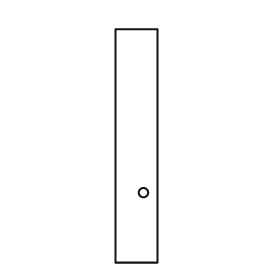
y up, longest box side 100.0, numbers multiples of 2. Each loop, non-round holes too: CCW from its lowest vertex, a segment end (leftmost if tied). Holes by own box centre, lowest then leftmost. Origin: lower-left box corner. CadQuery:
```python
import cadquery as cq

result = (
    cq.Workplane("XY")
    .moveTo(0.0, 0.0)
    .lineTo(18.0, 0.0)
    .lineTo(18.0, 100.0)
    .lineTo(0.0, 100.0)
    .close()
    .moveTo(12.0, 30.0)
    .circle(2.0)
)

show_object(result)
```